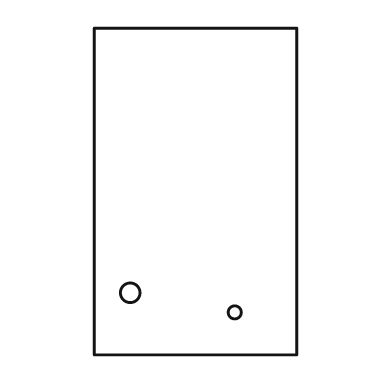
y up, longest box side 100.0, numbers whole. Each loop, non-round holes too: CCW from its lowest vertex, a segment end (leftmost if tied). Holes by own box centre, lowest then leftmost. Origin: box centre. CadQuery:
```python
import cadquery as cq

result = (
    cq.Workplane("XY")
    .moveTo(-31.0, -50.0)
    .lineTo(31.0, -50.0)
    .lineTo(31.0, 50.0)
    .lineTo(-31.0, 50.0)
    .close()
    .moveTo(12.0, -37.0)
    .circle(2.0)
    .moveTo(-20.0, -31.0)
    .circle(3.0)
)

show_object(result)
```